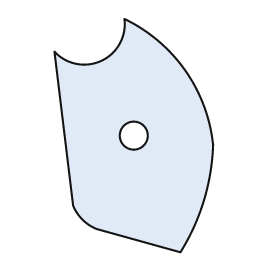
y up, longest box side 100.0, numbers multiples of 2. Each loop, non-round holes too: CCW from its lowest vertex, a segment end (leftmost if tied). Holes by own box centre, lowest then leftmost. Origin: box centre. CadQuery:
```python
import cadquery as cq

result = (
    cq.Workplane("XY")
    .moveTo(20.0, -50.0)
    .threePointArc((30.0, -28.0), (34.0, -4.0))
    .threePointArc((22.0, 28.0), (-4.0, 50.0))
    .threePointArc((-14.0, 32.0), (-34.0, 36.0))
    .lineTo(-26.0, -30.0)
    .threePointArc((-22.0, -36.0), (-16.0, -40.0))
    .close()
    .moveTo(0.0, 0.0)
    .circle(6.0)
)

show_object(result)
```